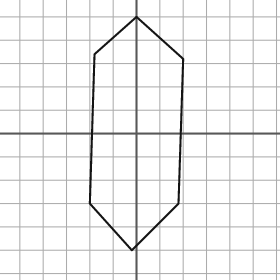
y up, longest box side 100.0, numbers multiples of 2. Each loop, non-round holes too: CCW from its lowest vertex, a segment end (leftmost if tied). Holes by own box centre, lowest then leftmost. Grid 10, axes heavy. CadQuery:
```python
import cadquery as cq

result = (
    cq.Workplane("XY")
    .moveTo(-2.0, -50.0)
    .lineTo(18.0, -30.0)
    .lineTo(20.0, 32.0)
    .lineTo(0.0, 50.0)
    .lineTo(-18.0, 34.0)
    .lineTo(-20.0, -30.0)
    .close()
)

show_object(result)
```